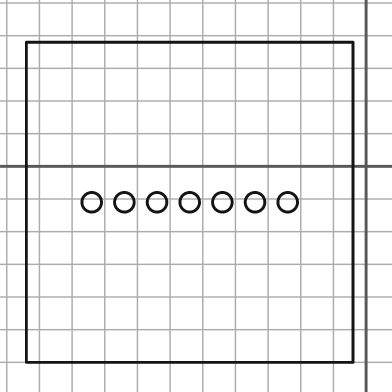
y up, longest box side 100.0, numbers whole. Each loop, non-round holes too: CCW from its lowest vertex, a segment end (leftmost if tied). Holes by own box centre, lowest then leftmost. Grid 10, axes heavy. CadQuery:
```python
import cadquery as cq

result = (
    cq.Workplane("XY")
    .moveTo(-104.0, -60.0)
    .lineTo(-4.0, -60.0)
    .lineTo(-4.0, 38.0)
    .lineTo(-104.0, 38.0)
    .close()
    .moveTo(-84.0, -11.0)
    .circle(3.0)
    .moveTo(-74.0, -11.0)
    .circle(3.0)
    .moveTo(-64.0, -11.0)
    .circle(3.0)
    .moveTo(-54.0, -11.0)
    .circle(3.0)
    .moveTo(-44.0, -11.0)
    .circle(3.0)
    .moveTo(-34.0, -11.0)
    .circle(3.0)
    .moveTo(-24.0, -11.0)
    .circle(3.0)
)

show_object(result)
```